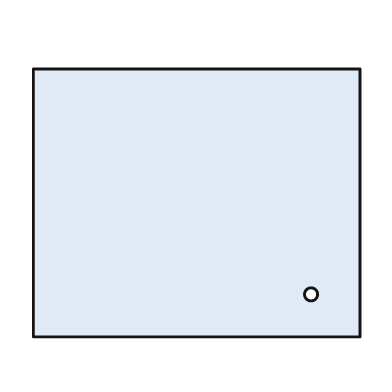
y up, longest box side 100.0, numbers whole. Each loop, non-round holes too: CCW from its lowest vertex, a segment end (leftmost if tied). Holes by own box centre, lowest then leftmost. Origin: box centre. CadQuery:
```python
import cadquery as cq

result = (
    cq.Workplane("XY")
    .moveTo(-50.0, -41.0)
    .lineTo(50.0, -41.0)
    .lineTo(50.0, 41.0)
    .lineTo(-50.0, 41.0)
    .close()
    .moveTo(35.0, -28.0)
    .circle(2.0)
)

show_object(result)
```